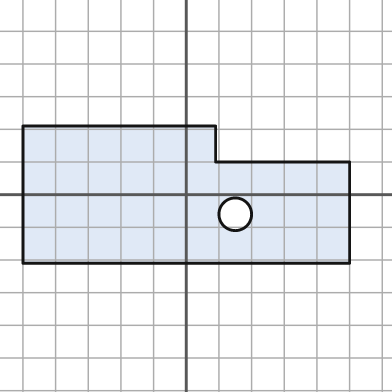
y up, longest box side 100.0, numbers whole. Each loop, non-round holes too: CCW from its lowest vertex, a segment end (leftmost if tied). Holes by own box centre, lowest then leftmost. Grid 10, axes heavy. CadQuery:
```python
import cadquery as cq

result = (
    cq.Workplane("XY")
    .moveTo(-50.0, -21.0)
    .lineTo(50.0, -21.0)
    .lineTo(50.0, 10.0)
    .lineTo(9.0, 10.0)
    .lineTo(9.0, 21.0)
    .lineTo(-50.0, 21.0)
    .close()
    .moveTo(15.0, -6.0)
    .circle(5.0)
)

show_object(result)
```